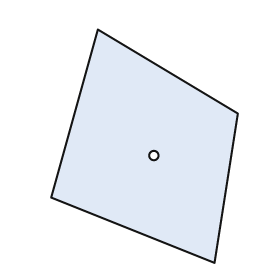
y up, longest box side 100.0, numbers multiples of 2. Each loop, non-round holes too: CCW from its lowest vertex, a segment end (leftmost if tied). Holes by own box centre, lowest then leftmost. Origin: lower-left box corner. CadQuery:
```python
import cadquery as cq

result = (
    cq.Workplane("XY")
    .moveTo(70.0, 0.0)
    .lineTo(80.0, 64.0)
    .lineTo(20.0, 100.0)
    .lineTo(0.0, 28.0)
    .close()
    .moveTo(44.0, 46.0)
    .circle(2.0)
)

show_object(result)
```